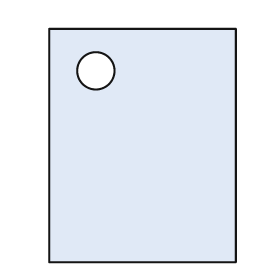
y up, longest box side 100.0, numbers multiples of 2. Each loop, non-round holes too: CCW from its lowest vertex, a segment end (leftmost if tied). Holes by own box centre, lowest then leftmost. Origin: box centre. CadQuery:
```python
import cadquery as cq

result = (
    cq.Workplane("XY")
    .moveTo(-40.0, -50.0)
    .lineTo(40.0, -50.0)
    .lineTo(40.0, 50.0)
    .lineTo(-40.0, 50.0)
    .close()
    .moveTo(-20.0, 32.0)
    .circle(8.0)
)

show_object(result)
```